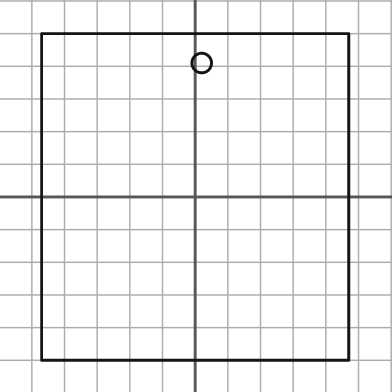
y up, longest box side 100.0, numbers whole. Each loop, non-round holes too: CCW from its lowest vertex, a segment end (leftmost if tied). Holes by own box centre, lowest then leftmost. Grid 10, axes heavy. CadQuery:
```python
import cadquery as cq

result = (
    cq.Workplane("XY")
    .moveTo(-47.0, -50.0)
    .lineTo(47.0, -50.0)
    .lineTo(47.0, 50.0)
    .lineTo(-47.0, 50.0)
    .close()
    .moveTo(2.0, 41.0)
    .circle(3.0)
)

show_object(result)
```